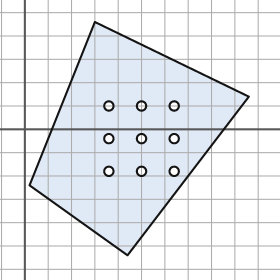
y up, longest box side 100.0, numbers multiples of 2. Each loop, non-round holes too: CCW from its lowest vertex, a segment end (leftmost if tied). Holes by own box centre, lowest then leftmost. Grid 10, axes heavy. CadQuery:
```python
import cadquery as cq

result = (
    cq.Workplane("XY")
    .moveTo(44.0, -54.0)
    .lineTo(96.0, 14.0)
    .lineTo(30.0, 46.0)
    .lineTo(2.0, -24.0)
    .close()
    .moveTo(36.0, -18.0)
    .circle(2.0)
    .moveTo(50.0, -18.0)
    .circle(2.0)
    .moveTo(64.0, -18.0)
    .circle(2.0)
    .moveTo(36.0, -4.0)
    .circle(2.0)
    .moveTo(50.0, -4.0)
    .circle(2.0)
    .moveTo(64.0, -4.0)
    .circle(2.0)
    .moveTo(36.0, 10.0)
    .circle(2.0)
    .moveTo(50.0, 10.0)
    .circle(2.0)
    .moveTo(64.0, 10.0)
    .circle(2.0)
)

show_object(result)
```